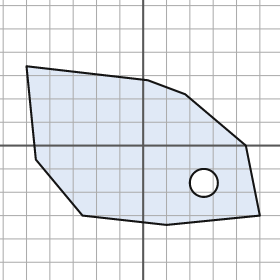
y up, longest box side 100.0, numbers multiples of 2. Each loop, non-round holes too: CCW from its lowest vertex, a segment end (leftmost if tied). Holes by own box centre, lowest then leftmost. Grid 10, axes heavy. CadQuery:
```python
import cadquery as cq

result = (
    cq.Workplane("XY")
    .moveTo(10.0, -34.0)
    .lineTo(50.0, -30.0)
    .lineTo(44.0, 0.0)
    .lineTo(18.0, 22.0)
    .lineTo(2.0, 28.0)
    .lineTo(-50.0, 34.0)
    .lineTo(-46.0, -6.0)
    .lineTo(-26.0, -30.0)
    .close()
    .moveTo(26.0, -16.0)
    .circle(6.0)
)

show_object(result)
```